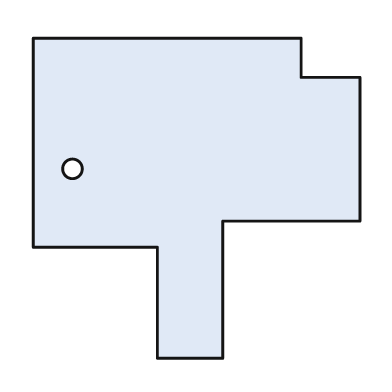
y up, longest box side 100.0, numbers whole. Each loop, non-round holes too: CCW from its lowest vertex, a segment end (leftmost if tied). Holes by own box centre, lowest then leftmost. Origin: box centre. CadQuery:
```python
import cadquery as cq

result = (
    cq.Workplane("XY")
    .moveTo(-12.0, -49.0)
    .lineTo(8.0, -49.0)
    .lineTo(8.0, -7.0)
    .lineTo(50.0, -7.0)
    .lineTo(50.0, 37.0)
    .lineTo(32.0, 37.0)
    .lineTo(32.0, 49.0)
    .lineTo(-50.0, 49.0)
    .lineTo(-50.0, -15.0)
    .lineTo(-12.0, -15.0)
    .close()
    .moveTo(-38.0, 9.0)
    .circle(3.0)
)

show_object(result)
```